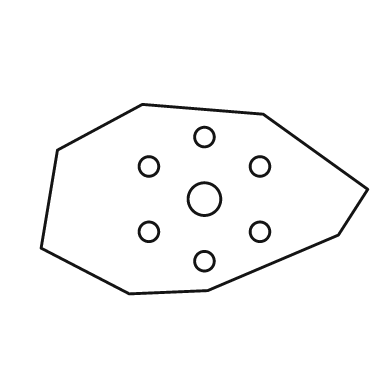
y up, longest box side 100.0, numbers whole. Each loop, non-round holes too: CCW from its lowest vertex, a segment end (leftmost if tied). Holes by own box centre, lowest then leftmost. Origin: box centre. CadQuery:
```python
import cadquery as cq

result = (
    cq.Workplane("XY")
    .moveTo(-23.0, -29.0)
    .lineTo(1.0, -28.0)
    .lineTo(41.0, -11.0)
    .lineTo(50.0, 3.0)
    .lineTo(18.0, 26.0)
    .lineTo(-19.0, 29.0)
    .lineTo(-45.0, 15.0)
    .lineTo(-50.0, -15.0)
    .close()
    .moveTo(0.0, -19.0)
    .circle(3.0)
    .moveTo(-17.0, -10.0)
    .circle(3.0)
    .moveTo(17.0, -10.0)
    .circle(3.0)
    .moveTo(0.0, 0.0)
    .circle(5.0)
    .moveTo(-17.0, 10.0)
    .circle(3.0)
    .moveTo(17.0, 10.0)
    .circle(3.0)
    .moveTo(0.0, 19.0)
    .circle(3.0)
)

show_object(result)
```